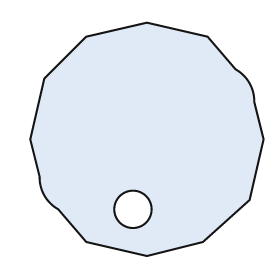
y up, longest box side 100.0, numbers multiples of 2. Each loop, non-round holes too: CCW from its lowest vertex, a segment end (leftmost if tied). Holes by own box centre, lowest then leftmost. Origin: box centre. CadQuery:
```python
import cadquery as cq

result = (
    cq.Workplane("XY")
    .moveTo(0.0, -50.0)
    .lineTo(24.0, -44.0)
    .lineTo(44.0, -26.0)
    .lineTo(50.0, 0.0)
    .lineTo(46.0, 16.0)
    .threePointArc((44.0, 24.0), (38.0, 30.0))
    .lineTo(26.0, 44.0)
    .lineTo(0.0, 50.0)
    .lineTo(-26.0, 44.0)
    .lineTo(-44.0, 26.0)
    .lineTo(-50.0, 0.0)
    .lineTo(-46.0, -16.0)
    .threePointArc((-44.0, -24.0), (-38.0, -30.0))
    .lineTo(-26.0, -44.0)
    .close()
    .moveTo(-6.0, -30.0)
    .circle(8.0)
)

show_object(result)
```